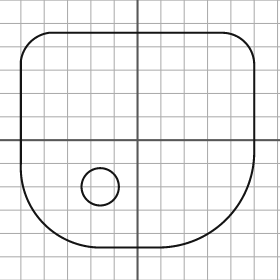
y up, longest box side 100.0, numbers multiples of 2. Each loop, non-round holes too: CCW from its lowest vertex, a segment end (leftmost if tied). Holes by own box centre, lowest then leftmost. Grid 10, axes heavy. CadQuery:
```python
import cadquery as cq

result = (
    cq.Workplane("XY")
    .moveTo(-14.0, -46.0)
    .lineTo(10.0, -46.0)
    .threePointArc((38.0, -34.0), (50.0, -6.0))
    .lineTo(50.0, 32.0)
    .threePointArc((46.0, 42.0), (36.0, 46.0))
    .lineTo(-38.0, 46.0)
    .threePointArc((-46.0, 42.0), (-50.0, 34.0))
    .lineTo(-50.0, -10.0)
    .threePointArc((-40.0, -36.0), (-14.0, -46.0))
    .close()
    .moveTo(-16.0, -20.0)
    .circle(8.0)
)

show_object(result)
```